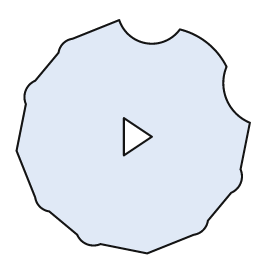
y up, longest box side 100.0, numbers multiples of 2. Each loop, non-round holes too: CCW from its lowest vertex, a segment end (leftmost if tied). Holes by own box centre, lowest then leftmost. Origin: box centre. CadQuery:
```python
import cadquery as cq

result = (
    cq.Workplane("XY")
    .moveTo(6.0, -50.0)
    .lineTo(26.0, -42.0)
    .threePointArc((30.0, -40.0), (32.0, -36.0))
    .lineTo(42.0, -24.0)
    .threePointArc((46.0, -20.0), (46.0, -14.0))
    .lineTo(50.0, 6.0)
    .threePointArc((40.0, 16.0), (40.0, 30.0))
    .threePointArc((32.0, 40.0), (20.0, 46.0))
    .threePointArc((6.0, 40.0), (-6.0, 50.0))
    .lineTo(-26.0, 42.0)
    .threePointArc((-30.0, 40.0), (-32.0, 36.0))
    .lineTo(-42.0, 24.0)
    .threePointArc((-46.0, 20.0), (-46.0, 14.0))
    .lineTo(-50.0, -6.0)
    .lineTo(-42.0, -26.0)
    .threePointArc((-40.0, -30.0), (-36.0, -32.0))
    .lineTo(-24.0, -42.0)
    .threePointArc((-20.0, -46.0), (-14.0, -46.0))
    .close()
    .moveTo(-4.0, -8.0)
    .lineTo(8.0, 0.0)
    .lineTo(-4.0, 8.0)
    .close()
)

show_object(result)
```